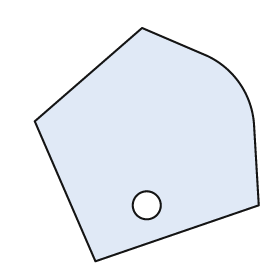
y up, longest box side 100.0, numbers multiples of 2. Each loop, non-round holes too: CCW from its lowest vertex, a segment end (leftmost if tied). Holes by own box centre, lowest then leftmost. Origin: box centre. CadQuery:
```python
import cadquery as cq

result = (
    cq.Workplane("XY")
    .moveTo(-22.0, -50.0)
    .lineTo(48.0, -26.0)
    .lineTo(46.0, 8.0)
    .threePointArc((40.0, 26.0), (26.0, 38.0))
    .lineTo(-2.0, 50.0)
    .lineTo(-48.0, 10.0)
    .close()
    .moveTo(0.0, -26.0)
    .circle(6.0)
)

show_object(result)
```